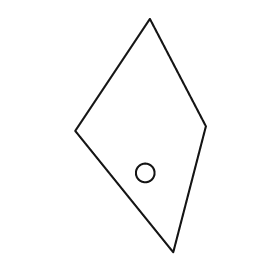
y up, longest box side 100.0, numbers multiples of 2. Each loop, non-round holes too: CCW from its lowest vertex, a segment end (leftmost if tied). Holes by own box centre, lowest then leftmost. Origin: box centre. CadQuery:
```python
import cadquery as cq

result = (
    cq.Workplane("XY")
    .moveTo(14.0, -50.0)
    .lineTo(28.0, 4.0)
    .lineTo(4.0, 50.0)
    .lineTo(-28.0, 2.0)
    .close()
    .moveTo(2.0, -16.0)
    .circle(4.0)
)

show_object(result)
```